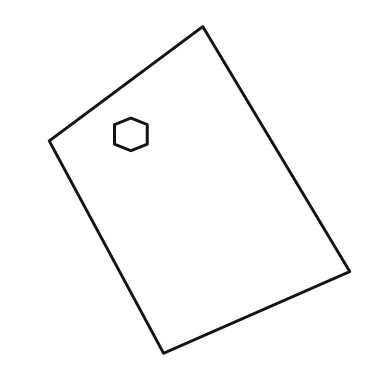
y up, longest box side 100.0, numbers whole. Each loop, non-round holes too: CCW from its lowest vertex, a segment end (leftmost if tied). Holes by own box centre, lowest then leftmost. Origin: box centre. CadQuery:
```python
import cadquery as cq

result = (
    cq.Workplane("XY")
    .moveTo(-11.0, -50.0)
    .lineTo(46.0, -25.0)
    .lineTo(1.0, 50.0)
    .lineTo(-46.0, 15.0)
    .close()
    .moveTo(-21.0, 12.0)
    .lineTo(-16.0, 14.0)
    .lineTo(-16.0, 20.0)
    .lineTo(-21.0, 22.0)
    .lineTo(-26.0, 20.0)
    .lineTo(-26.0, 14.0)
    .close()
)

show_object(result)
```